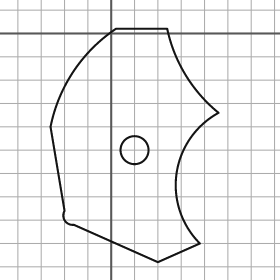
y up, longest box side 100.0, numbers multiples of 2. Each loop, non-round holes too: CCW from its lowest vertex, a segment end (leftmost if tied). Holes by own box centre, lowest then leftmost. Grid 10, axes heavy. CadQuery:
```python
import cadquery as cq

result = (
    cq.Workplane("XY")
    .moveTo(20.0, -98.0)
    .lineTo(38.0, -90.0)
    .threePointArc((28.0, -60.0), (46.0, -34.0))
    .threePointArc((32.0, -18.0), (24.0, 2.0))
    .lineTo(2.0, 2.0)
    .threePointArc((-16.0, -16.0), (-26.0, -40.0))
    .lineTo(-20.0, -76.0)
    .threePointArc((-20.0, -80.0), (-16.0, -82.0))
    .close()
    .moveTo(10.0, -50.0)
    .circle(6.0)
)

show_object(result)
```